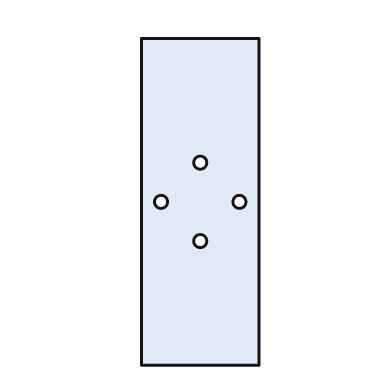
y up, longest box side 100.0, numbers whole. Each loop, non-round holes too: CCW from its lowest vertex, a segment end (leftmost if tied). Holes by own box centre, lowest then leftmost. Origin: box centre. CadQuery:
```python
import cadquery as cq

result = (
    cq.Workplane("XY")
    .moveTo(-18.0, -50.0)
    .lineTo(18.0, -50.0)
    .lineTo(18.0, 50.0)
    .lineTo(-18.0, 50.0)
    .close()
    .moveTo(0.0, -12.0)
    .circle(2.0)
    .moveTo(-12.0, 0.0)
    .circle(2.0)
    .moveTo(12.0, 0.0)
    .circle(2.0)
    .moveTo(0.0, 12.0)
    .circle(2.0)
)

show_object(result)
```